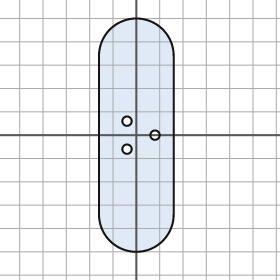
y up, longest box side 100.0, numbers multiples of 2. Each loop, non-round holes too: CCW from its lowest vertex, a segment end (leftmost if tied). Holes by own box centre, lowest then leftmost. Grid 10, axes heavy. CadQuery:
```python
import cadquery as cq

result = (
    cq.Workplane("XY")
    .moveTo(-16.0, -34.0)
    .threePointArc((0.0, -50.0), (16.0, -34.0))
    .lineTo(16.0, 34.0)
    .threePointArc((0.0, 50.0), (-16.0, 34.0))
    .close()
    .moveTo(-4.0, -6.0)
    .circle(2.0)
    .moveTo(8.0, 0.0)
    .circle(2.0)
    .moveTo(-4.0, 6.0)
    .circle(2.0)
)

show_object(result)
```